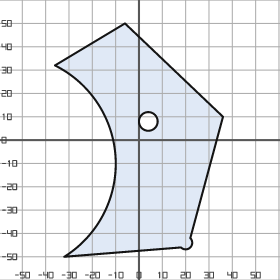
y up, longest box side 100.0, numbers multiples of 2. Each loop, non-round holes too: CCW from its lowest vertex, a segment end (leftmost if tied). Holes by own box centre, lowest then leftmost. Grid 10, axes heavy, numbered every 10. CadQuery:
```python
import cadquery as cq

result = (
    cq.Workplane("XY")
    .moveTo(-32.0, -50.0)
    .lineTo(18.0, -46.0)
    .threePointArc((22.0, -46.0), (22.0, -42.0))
    .lineTo(36.0, 10.0)
    .lineTo(-6.0, 50.0)
    .lineTo(-36.0, 32.0)
    .threePointArc((-10.0, -8.0), (-32.0, -50.0))
    .close()
    .moveTo(4.0, 8.0)
    .circle(4.0)
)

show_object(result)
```